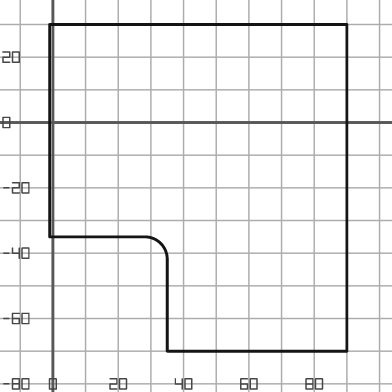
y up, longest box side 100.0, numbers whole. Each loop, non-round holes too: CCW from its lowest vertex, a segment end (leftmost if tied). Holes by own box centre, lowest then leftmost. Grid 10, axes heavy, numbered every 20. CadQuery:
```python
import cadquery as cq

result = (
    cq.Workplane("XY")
    .moveTo(35.0, -70.0)
    .lineTo(90.0, -70.0)
    .lineTo(90.0, 30.0)
    .lineTo(-1.0, 30.0)
    .lineTo(-1.0, -35.0)
    .lineTo(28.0, -35.0)
    .threePointArc((33.0, -37.0), (35.0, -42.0))
    .close()
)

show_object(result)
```